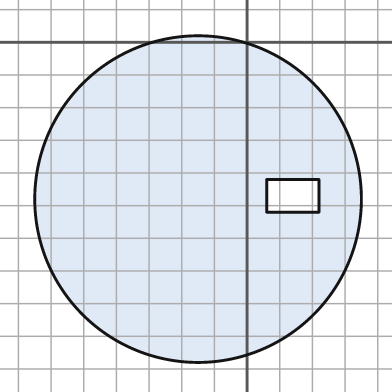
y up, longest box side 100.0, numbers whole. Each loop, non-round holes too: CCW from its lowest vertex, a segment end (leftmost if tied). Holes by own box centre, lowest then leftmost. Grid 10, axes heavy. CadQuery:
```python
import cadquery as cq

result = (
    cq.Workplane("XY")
    .moveTo(-15.0, -48.0)
    .circle(50.0)
    .moveTo(6.0, -52.0)
    .lineTo(22.0, -52.0)
    .lineTo(22.0, -42.0)
    .lineTo(6.0, -42.0)
    .close()
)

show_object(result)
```